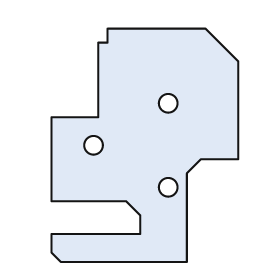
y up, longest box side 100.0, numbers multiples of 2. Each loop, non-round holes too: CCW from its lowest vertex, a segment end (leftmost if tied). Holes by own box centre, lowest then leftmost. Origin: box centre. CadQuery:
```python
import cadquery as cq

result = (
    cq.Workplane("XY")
    .moveTo(-36.0, -50.0)
    .lineTo(18.0, -50.0)
    .lineTo(18.0, -12.0)
    .lineTo(24.0, -6.0)
    .lineTo(40.0, -6.0)
    .lineTo(40.0, 36.0)
    .lineTo(26.0, 50.0)
    .lineTo(-16.0, 50.0)
    .lineTo(-16.0, 44.0)
    .lineTo(-20.0, 44.0)
    .lineTo(-20.0, 12.0)
    .lineTo(-40.0, 12.0)
    .lineTo(-40.0, -24.0)
    .lineTo(-8.0, -24.0)
    .lineTo(-2.0, -30.0)
    .lineTo(-2.0, -38.0)
    .lineTo(-40.0, -38.0)
    .lineTo(-40.0, -46.0)
    .close()
    .moveTo(10.0, -18.0)
    .circle(4.0)
    .moveTo(-22.0, 0.0)
    .circle(4.0)
    .moveTo(10.0, 18.0)
    .circle(4.0)
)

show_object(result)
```